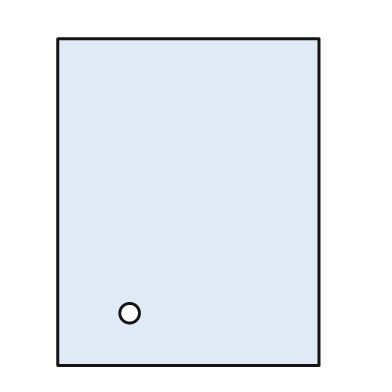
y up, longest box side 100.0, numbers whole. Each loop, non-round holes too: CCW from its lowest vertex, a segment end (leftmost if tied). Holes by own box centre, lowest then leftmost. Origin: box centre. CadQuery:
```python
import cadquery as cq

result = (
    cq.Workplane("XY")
    .moveTo(-40.0, -50.0)
    .lineTo(40.0, -50.0)
    .lineTo(40.0, 50.0)
    .lineTo(-40.0, 50.0)
    .close()
    .moveTo(-18.0, -34.0)
    .circle(3.0)
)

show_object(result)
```